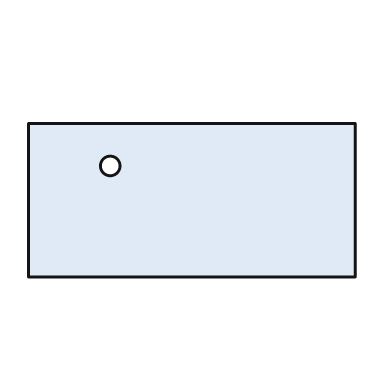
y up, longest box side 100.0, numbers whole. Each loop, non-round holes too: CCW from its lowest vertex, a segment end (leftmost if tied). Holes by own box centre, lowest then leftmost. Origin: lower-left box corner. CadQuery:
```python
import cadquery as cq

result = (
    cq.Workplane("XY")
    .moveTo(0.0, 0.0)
    .lineTo(100.0, 0.0)
    .lineTo(100.0, 47.0)
    .lineTo(0.0, 47.0)
    .close()
    .moveTo(25.0, 34.0)
    .circle(3.0)
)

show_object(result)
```